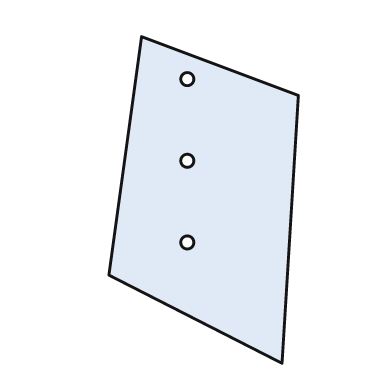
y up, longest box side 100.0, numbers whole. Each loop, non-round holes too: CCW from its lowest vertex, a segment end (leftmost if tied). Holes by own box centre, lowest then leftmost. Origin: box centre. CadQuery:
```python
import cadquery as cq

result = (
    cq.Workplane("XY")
    .moveTo(24.0, -50.0)
    .lineTo(29.0, 32.0)
    .lineTo(-19.0, 50.0)
    .lineTo(-29.0, -23.0)
    .close()
    .moveTo(-5.0, -13.0)
    .circle(2.0)
    .moveTo(-5.0, 12.0)
    .circle(2.0)
    .moveTo(-5.0, 37.0)
    .circle(2.0)
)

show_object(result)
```